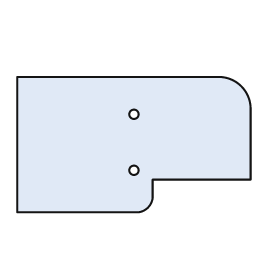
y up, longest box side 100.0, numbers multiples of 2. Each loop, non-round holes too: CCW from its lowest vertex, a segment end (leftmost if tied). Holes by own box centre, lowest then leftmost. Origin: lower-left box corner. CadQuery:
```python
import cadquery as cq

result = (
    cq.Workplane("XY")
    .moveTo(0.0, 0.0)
    .lineTo(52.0, 0.0)
    .threePointArc((56.0, 2.0), (58.0, 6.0))
    .lineTo(58.0, 14.0)
    .lineTo(100.0, 14.0)
    .lineTo(100.0, 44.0)
    .threePointArc((96.0, 54.0), (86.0, 58.0))
    .lineTo(0.0, 58.0)
    .close()
    .moveTo(50.0, 18.0)
    .circle(2.0)
    .moveTo(50.0, 42.0)
    .circle(2.0)
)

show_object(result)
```